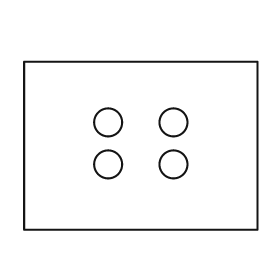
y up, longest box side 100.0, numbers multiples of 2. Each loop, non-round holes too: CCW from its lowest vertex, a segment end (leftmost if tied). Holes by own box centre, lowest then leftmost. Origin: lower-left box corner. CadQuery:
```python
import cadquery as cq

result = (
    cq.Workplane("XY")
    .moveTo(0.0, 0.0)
    .lineTo(100.0, 0.0)
    .lineTo(100.0, 72.0)
    .lineTo(0.0, 72.0)
    .close()
    .moveTo(36.0, 28.0)
    .circle(6.0)
    .moveTo(64.0, 28.0)
    .circle(6.0)
    .moveTo(36.0, 46.0)
    .circle(6.0)
    .moveTo(64.0, 46.0)
    .circle(6.0)
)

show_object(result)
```